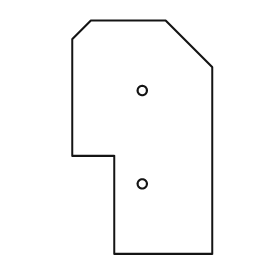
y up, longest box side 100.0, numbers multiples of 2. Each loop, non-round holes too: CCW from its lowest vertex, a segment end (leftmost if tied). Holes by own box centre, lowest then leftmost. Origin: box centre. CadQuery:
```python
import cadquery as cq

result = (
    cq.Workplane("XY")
    .moveTo(-12.0, -50.0)
    .lineTo(30.0, -50.0)
    .lineTo(30.0, 30.0)
    .lineTo(10.0, 50.0)
    .lineTo(-22.0, 50.0)
    .lineTo(-30.0, 42.0)
    .lineTo(-30.0, -8.0)
    .lineTo(-12.0, -8.0)
    .close()
    .moveTo(0.0, -20.0)
    .circle(2.0)
    .moveTo(0.0, 20.0)
    .circle(2.0)
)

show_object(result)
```